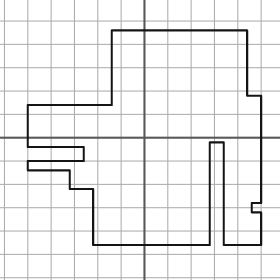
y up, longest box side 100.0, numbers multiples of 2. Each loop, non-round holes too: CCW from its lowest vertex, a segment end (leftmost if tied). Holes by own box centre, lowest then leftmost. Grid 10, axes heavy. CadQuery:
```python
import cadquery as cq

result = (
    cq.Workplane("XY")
    .moveTo(-22.0, -46.0)
    .lineTo(28.0, -46.0)
    .lineTo(28.0, -2.0)
    .lineTo(34.0, -2.0)
    .lineTo(34.0, -46.0)
    .lineTo(50.0, -46.0)
    .lineTo(50.0, -32.0)
    .lineTo(46.0, -32.0)
    .lineTo(46.0, -28.0)
    .lineTo(50.0, -28.0)
    .lineTo(50.0, 18.0)
    .lineTo(44.0, 18.0)
    .lineTo(44.0, 46.0)
    .lineTo(-14.0, 46.0)
    .lineTo(-14.0, 14.0)
    .lineTo(-50.0, 14.0)
    .lineTo(-50.0, -4.0)
    .lineTo(-26.0, -4.0)
    .lineTo(-26.0, -10.0)
    .lineTo(-50.0, -10.0)
    .lineTo(-50.0, -14.0)
    .lineTo(-32.0, -14.0)
    .lineTo(-32.0, -22.0)
    .lineTo(-22.0, -22.0)
    .close()
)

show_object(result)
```